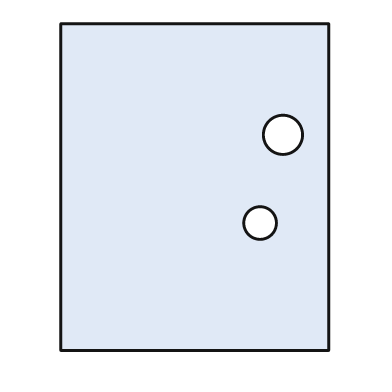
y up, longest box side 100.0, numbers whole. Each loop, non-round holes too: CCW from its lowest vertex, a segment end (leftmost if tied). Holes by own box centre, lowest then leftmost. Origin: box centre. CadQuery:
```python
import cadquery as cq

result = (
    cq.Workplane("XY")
    .moveTo(-41.0, -50.0)
    .lineTo(41.0, -50.0)
    .lineTo(41.0, 50.0)
    .lineTo(-41.0, 50.0)
    .close()
    .moveTo(20.0, -11.0)
    .circle(5.0)
    .moveTo(27.0, 16.0)
    .circle(6.0)
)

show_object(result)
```